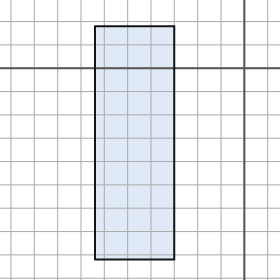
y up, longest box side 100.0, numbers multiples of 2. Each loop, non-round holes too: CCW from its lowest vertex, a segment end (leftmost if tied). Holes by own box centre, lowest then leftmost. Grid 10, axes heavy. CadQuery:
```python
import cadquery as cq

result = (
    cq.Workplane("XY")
    .moveTo(-64.0, -82.0)
    .lineTo(-30.0, -82.0)
    .lineTo(-30.0, 18.0)
    .lineTo(-64.0, 18.0)
    .close()
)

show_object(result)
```